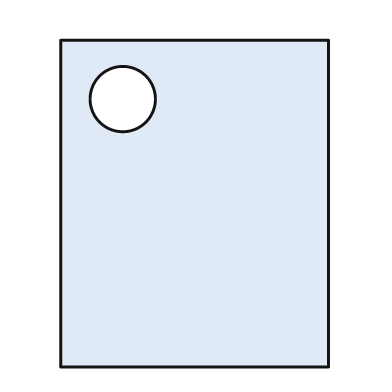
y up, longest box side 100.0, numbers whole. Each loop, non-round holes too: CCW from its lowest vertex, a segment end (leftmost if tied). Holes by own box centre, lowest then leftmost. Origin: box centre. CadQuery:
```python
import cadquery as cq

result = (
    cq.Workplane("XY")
    .moveTo(-41.0, -50.0)
    .lineTo(41.0, -50.0)
    .lineTo(41.0, 50.0)
    .lineTo(-41.0, 50.0)
    .close()
    .moveTo(-22.0, 32.0)
    .circle(10.0)
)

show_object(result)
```